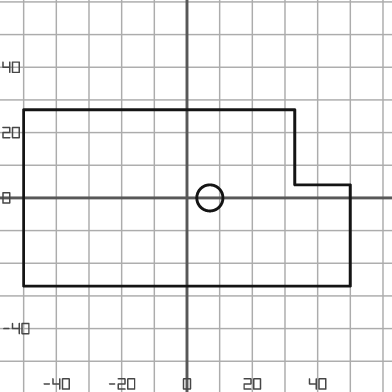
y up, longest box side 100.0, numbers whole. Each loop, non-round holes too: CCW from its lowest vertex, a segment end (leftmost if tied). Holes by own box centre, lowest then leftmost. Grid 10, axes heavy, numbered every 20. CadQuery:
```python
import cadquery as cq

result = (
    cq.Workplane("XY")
    .moveTo(-50.0, -27.0)
    .lineTo(50.0, -27.0)
    .lineTo(50.0, 4.0)
    .lineTo(33.0, 4.0)
    .lineTo(33.0, 27.0)
    .lineTo(-50.0, 27.0)
    .close()
    .moveTo(7.0, 0.0)
    .circle(4.0)
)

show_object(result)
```